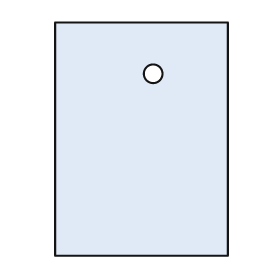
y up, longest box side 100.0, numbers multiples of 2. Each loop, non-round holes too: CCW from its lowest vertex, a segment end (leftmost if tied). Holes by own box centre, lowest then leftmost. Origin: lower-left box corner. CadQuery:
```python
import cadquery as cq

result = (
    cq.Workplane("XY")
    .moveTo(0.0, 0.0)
    .lineTo(74.0, 0.0)
    .lineTo(74.0, 100.0)
    .lineTo(0.0, 100.0)
    .close()
    .moveTo(42.0, 78.0)
    .circle(4.0)
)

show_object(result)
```